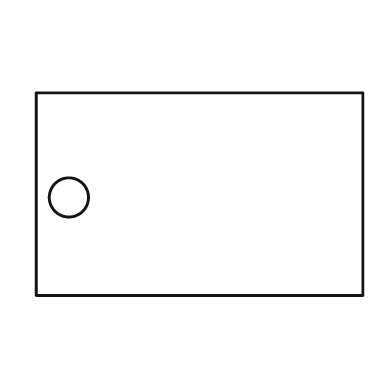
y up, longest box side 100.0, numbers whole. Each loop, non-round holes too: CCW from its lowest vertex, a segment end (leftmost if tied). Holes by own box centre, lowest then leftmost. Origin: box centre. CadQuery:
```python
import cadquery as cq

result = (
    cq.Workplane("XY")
    .moveTo(-50.0, -31.0)
    .lineTo(50.0, -31.0)
    .lineTo(50.0, 31.0)
    .lineTo(-50.0, 31.0)
    .close()
    .moveTo(-40.0, -1.0)
    .circle(6.0)
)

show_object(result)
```